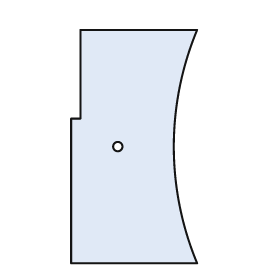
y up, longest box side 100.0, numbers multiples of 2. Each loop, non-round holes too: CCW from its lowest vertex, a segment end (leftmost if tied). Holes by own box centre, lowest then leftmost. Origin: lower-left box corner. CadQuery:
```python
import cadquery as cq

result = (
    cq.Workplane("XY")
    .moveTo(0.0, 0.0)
    .lineTo(54.0, 0.0)
    .threePointArc((44.0, 50.0), (54.0, 100.0))
    .lineTo(4.0, 100.0)
    .lineTo(4.0, 62.0)
    .lineTo(0.0, 62.0)
    .close()
    .moveTo(20.0, 50.0)
    .circle(2.0)
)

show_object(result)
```